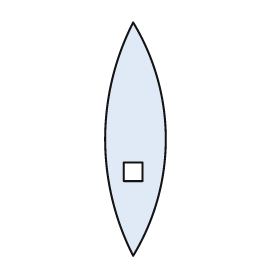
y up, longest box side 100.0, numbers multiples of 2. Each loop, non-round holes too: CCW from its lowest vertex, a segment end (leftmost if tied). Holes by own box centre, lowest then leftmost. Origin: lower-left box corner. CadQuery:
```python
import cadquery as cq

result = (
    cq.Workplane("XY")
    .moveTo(12.0, 0.0)
    .threePointArc((26.0, 50.0), (12.0, 100.0))
    .threePointArc((0.0, 50.0), (12.0, 0.0))
    .close()
    .moveTo(8.0, 32.0)
    .lineTo(16.0, 32.0)
    .lineTo(16.0, 40.0)
    .lineTo(8.0, 40.0)
    .close()
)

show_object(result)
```